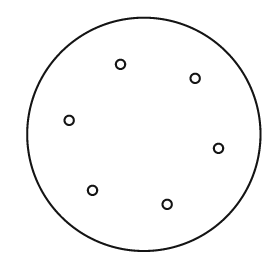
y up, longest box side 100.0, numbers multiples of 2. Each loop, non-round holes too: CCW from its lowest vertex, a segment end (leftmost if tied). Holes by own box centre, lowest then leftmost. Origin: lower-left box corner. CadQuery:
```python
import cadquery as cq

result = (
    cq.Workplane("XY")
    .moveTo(50.0, 50.0)
    .circle(50.0)
    .moveTo(60.0, 20.0)
    .circle(2.0)
    .moveTo(28.0, 26.0)
    .circle(2.0)
    .moveTo(82.0, 44.0)
    .circle(2.0)
    .moveTo(18.0, 56.0)
    .circle(2.0)
    .moveTo(72.0, 74.0)
    .circle(2.0)
    .moveTo(40.0, 80.0)
    .circle(2.0)
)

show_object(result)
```